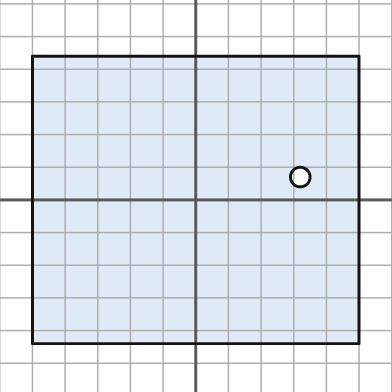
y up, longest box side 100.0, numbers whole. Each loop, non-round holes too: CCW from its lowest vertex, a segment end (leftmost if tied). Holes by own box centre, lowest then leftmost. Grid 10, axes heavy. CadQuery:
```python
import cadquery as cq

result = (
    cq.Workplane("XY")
    .moveTo(-50.0, -44.0)
    .lineTo(50.0, -44.0)
    .lineTo(50.0, 44.0)
    .lineTo(-50.0, 44.0)
    .close()
    .moveTo(32.0, 7.0)
    .circle(3.0)
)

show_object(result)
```